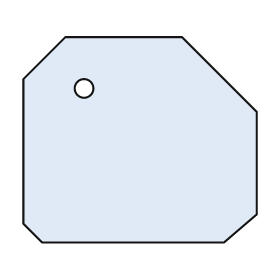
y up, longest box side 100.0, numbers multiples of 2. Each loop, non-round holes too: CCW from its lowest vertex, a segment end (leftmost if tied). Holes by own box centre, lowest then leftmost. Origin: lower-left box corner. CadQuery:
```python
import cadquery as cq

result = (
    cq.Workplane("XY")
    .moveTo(8.0, 0.0)
    .lineTo(86.0, 0.0)
    .lineTo(100.0, 12.0)
    .lineTo(100.0, 56.0)
    .lineTo(68.0, 88.0)
    .lineTo(18.0, 88.0)
    .lineTo(0.0, 70.0)
    .lineTo(0.0, 8.0)
    .close()
    .moveTo(26.0, 66.0)
    .circle(4.0)
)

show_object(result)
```